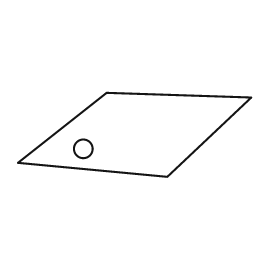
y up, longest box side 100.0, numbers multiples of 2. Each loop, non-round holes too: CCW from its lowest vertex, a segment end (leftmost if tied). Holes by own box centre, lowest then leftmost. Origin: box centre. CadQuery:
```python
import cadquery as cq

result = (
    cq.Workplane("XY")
    .moveTo(14.0, -18.0)
    .lineTo(50.0, 16.0)
    .lineTo(-12.0, 18.0)
    .lineTo(-50.0, -12.0)
    .close()
    .moveTo(-22.0, -6.0)
    .circle(4.0)
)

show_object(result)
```